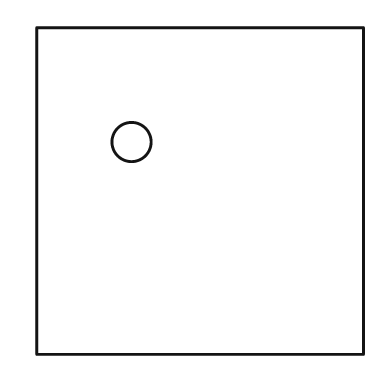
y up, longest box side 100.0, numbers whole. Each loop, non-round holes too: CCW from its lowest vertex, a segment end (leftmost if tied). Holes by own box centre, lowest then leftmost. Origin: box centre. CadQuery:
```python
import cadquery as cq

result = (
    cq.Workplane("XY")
    .moveTo(-50.0, -50.0)
    .lineTo(50.0, -50.0)
    .lineTo(50.0, 50.0)
    .lineTo(-50.0, 50.0)
    .close()
    .moveTo(-21.0, 15.0)
    .circle(6.0)
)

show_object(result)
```